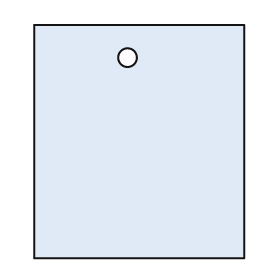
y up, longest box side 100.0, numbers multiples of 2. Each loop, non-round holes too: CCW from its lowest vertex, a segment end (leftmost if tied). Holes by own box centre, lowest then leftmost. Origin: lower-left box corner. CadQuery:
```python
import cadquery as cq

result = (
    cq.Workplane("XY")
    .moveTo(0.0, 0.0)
    .lineTo(90.0, 0.0)
    .lineTo(90.0, 100.0)
    .lineTo(0.0, 100.0)
    .close()
    .moveTo(40.0, 86.0)
    .circle(4.0)
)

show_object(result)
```